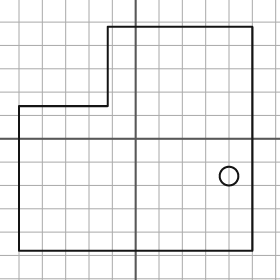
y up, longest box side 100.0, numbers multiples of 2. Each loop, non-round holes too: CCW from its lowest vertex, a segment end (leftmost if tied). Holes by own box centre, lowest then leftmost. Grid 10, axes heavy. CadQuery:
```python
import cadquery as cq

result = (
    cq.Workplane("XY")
    .moveTo(-50.0, -48.0)
    .lineTo(50.0, -48.0)
    .lineTo(50.0, 48.0)
    .lineTo(-12.0, 48.0)
    .lineTo(-12.0, 14.0)
    .lineTo(-50.0, 14.0)
    .close()
    .moveTo(40.0, -16.0)
    .circle(4.0)
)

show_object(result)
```